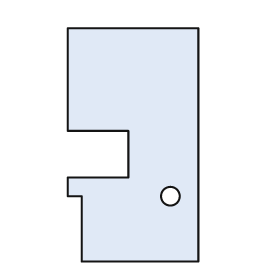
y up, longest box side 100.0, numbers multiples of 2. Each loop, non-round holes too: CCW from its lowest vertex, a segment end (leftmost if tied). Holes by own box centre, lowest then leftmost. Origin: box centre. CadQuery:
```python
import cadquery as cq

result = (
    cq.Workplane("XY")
    .moveTo(-22.0, -50.0)
    .lineTo(28.0, -50.0)
    .lineTo(28.0, 50.0)
    .lineTo(-28.0, 50.0)
    .lineTo(-28.0, 6.0)
    .lineTo(-2.0, 6.0)
    .lineTo(-2.0, -14.0)
    .lineTo(-28.0, -14.0)
    .lineTo(-28.0, -22.0)
    .lineTo(-22.0, -22.0)
    .close()
    .moveTo(16.0, -22.0)
    .circle(4.0)
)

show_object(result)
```